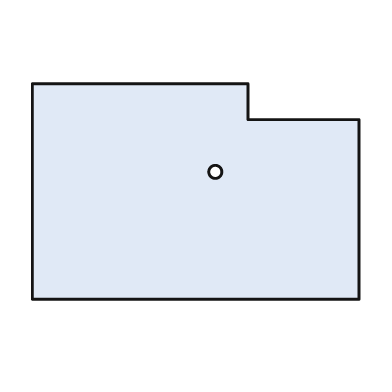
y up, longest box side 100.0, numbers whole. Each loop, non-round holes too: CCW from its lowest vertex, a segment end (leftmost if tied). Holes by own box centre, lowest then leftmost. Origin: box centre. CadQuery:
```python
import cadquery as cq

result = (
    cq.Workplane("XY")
    .moveTo(-50.0, -33.0)
    .lineTo(50.0, -33.0)
    .lineTo(50.0, 22.0)
    .lineTo(16.0, 22.0)
    .lineTo(16.0, 33.0)
    .lineTo(-50.0, 33.0)
    .close()
    .moveTo(6.0, 6.0)
    .circle(2.0)
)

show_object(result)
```